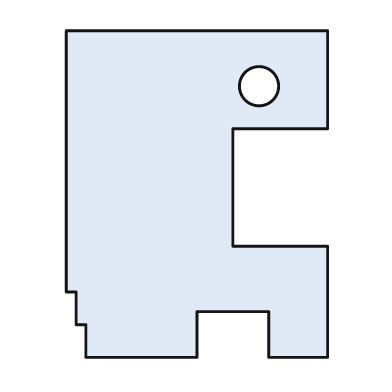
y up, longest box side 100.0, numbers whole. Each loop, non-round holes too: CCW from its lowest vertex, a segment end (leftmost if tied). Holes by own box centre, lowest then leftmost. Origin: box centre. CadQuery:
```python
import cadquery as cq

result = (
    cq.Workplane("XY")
    .moveTo(-34.0, -50.0)
    .lineTo(0.0, -50.0)
    .lineTo(0.0, -36.0)
    .lineTo(22.0, -36.0)
    .lineTo(22.0, -50.0)
    .lineTo(40.0, -50.0)
    .lineTo(40.0, -16.0)
    .lineTo(11.0, -16.0)
    .lineTo(11.0, 20.0)
    .lineTo(40.0, 20.0)
    .lineTo(40.0, 50.0)
    .lineTo(-40.0, 50.0)
    .lineTo(-40.0, -30.0)
    .lineTo(-37.0, -30.0)
    .lineTo(-37.0, -40.0)
    .lineTo(-34.0, -40.0)
    .close()
    .moveTo(19.0, 33.0)
    .circle(6.0)
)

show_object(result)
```